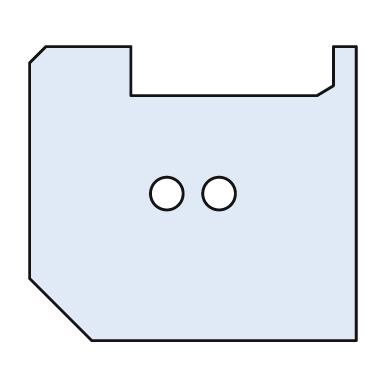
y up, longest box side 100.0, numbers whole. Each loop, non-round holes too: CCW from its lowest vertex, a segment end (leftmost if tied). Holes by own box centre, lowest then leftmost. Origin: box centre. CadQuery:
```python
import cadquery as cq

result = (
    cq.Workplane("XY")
    .moveTo(-31.0, -45.0)
    .lineTo(50.0, -45.0)
    .lineTo(50.0, 45.0)
    .lineTo(43.0, 45.0)
    .lineTo(43.0, 33.0)
    .lineTo(38.0, 30.0)
    .lineTo(-19.0, 30.0)
    .lineTo(-19.0, 45.0)
    .lineTo(-45.0, 45.0)
    .lineTo(-50.0, 40.0)
    .lineTo(-50.0, -26.0)
    .close()
    .moveTo(-8.0, 0.0)
    .circle(5.0)
    .moveTo(8.0, 0.0)
    .circle(5.0)
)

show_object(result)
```